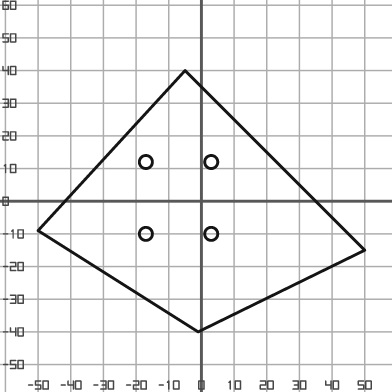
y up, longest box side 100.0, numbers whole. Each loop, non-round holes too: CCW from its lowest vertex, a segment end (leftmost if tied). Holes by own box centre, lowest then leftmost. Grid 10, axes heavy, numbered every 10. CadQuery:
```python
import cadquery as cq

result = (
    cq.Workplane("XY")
    .moveTo(-1.0, -40.0)
    .lineTo(50.0, -15.0)
    .lineTo(-5.0, 40.0)
    .lineTo(-50.0, -9.0)
    .close()
    .moveTo(-17.0, -10.0)
    .circle(2.0)
    .moveTo(3.0, -10.0)
    .circle(2.0)
    .moveTo(-17.0, 12.0)
    .circle(2.0)
    .moveTo(3.0, 12.0)
    .circle(2.0)
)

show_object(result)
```